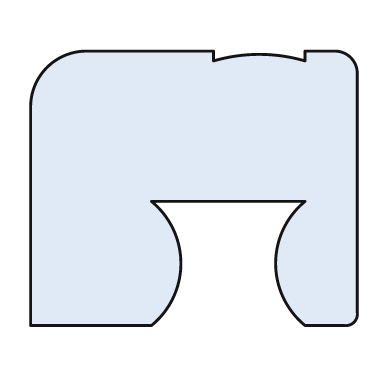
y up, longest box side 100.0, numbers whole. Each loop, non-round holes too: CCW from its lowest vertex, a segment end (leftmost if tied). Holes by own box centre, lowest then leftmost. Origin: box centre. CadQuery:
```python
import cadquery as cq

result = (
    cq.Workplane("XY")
    .moveTo(-50.0, -42.0)
    .lineTo(-13.0, -42.0)
    .threePointArc((-4.0, -23.0), (-13.0, -4.0))
    .lineTo(34.0, -4.0)
    .threePointArc((25.0, -23.0), (34.0, -42.0))
    .lineTo(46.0, -42.0)
    .threePointArc((49.0, -41.0), (50.0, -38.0))
    .lineTo(50.0, 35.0)
    .threePointArc((48.0, 40.0), (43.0, 42.0))
    .lineTo(34.0, 42.0)
    .lineTo(34.0, 39.0)
    .threePointArc((20.0, 41.0), (6.0, 39.0))
    .lineTo(6.0, 42.0)
    .lineTo(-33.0, 42.0)
    .threePointArc((-45.0, 37.0), (-50.0, 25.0))
    .close()
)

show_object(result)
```